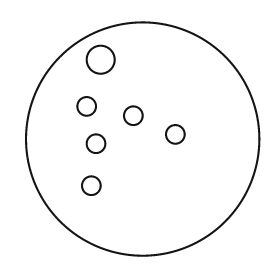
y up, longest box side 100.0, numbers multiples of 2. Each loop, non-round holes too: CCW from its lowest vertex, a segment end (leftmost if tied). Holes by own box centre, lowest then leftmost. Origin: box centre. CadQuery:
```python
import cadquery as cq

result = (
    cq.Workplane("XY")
    .moveTo(0.0, 0.0)
    .circle(50.0)
    .moveTo(-22.0, -20.0)
    .circle(4.0)
    .moveTo(-20.0, -2.0)
    .circle(4.0)
    .moveTo(14.0, 2.0)
    .circle(4.0)
    .moveTo(-4.0, 10.0)
    .circle(4.0)
    .moveTo(-24.0, 14.0)
    .circle(4.0)
    .moveTo(-18.0, 34.0)
    .circle(6.0)
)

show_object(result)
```